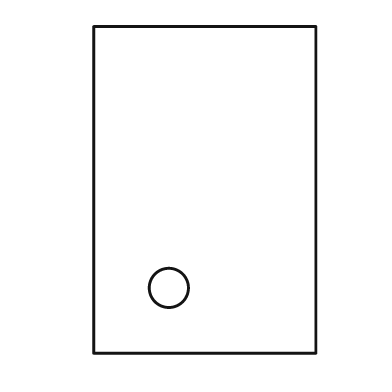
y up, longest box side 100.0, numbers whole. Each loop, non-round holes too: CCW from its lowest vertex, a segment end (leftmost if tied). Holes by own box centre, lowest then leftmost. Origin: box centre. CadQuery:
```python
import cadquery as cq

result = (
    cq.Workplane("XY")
    .moveTo(-34.0, -50.0)
    .lineTo(34.0, -50.0)
    .lineTo(34.0, 50.0)
    .lineTo(-34.0, 50.0)
    .close()
    .moveTo(-11.0, -30.0)
    .circle(6.0)
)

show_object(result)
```